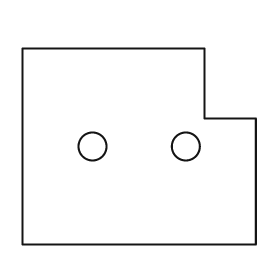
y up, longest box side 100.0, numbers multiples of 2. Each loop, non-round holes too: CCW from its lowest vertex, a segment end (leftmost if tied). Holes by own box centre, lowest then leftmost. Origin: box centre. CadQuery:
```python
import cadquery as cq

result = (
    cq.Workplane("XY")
    .moveTo(-50.0, -42.0)
    .lineTo(50.0, -42.0)
    .lineTo(50.0, 12.0)
    .lineTo(28.0, 12.0)
    .lineTo(28.0, 42.0)
    .lineTo(-50.0, 42.0)
    .close()
    .moveTo(-20.0, 0.0)
    .circle(6.0)
    .moveTo(20.0, 0.0)
    .circle(6.0)
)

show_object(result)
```